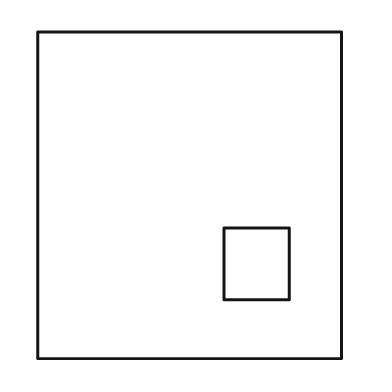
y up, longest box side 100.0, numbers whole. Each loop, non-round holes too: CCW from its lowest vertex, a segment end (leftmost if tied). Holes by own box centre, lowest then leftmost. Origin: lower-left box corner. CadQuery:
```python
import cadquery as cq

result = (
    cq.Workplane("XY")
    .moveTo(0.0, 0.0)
    .lineTo(93.0, 0.0)
    .lineTo(93.0, 100.0)
    .lineTo(0.0, 100.0)
    .close()
    .moveTo(57.0, 18.0)
    .lineTo(77.0, 18.0)
    .lineTo(77.0, 40.0)
    .lineTo(57.0, 40.0)
    .close()
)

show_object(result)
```